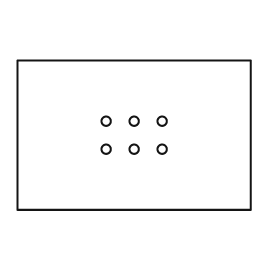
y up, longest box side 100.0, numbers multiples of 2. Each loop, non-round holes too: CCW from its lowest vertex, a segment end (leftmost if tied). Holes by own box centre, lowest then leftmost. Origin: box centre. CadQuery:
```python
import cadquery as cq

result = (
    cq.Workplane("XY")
    .moveTo(-50.0, -32.0)
    .lineTo(50.0, -32.0)
    .lineTo(50.0, 32.0)
    .lineTo(-50.0, 32.0)
    .close()
    .moveTo(-12.0, -6.0)
    .circle(2.0)
    .moveTo(0.0, -6.0)
    .circle(2.0)
    .moveTo(12.0, -6.0)
    .circle(2.0)
    .moveTo(-12.0, 6.0)
    .circle(2.0)
    .moveTo(0.0, 6.0)
    .circle(2.0)
    .moveTo(12.0, 6.0)
    .circle(2.0)
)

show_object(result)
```